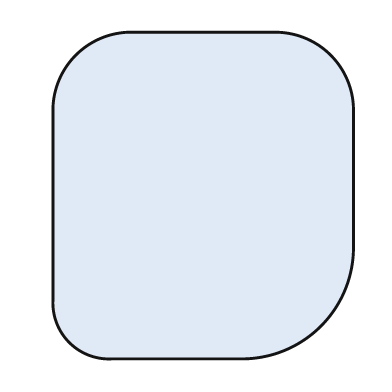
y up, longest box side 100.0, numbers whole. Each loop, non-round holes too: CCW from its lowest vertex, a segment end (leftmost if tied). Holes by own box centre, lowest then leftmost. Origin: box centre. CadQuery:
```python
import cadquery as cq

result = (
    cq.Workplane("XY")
    .moveTo(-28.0, -50.0)
    .lineTo(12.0, -50.0)
    .threePointArc((36.0, -40.0), (46.0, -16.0))
    .lineTo(46.0, 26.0)
    .threePointArc((39.0, 43.0), (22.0, 50.0))
    .lineTo(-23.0, 50.0)
    .threePointArc((-39.0, 43.0), (-46.0, 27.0))
    .lineTo(-46.0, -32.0)
    .threePointArc((-41.0, -45.0), (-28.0, -50.0))
    .close()
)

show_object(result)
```